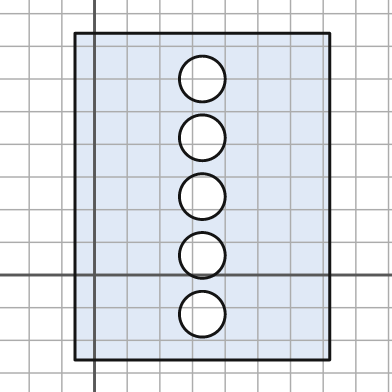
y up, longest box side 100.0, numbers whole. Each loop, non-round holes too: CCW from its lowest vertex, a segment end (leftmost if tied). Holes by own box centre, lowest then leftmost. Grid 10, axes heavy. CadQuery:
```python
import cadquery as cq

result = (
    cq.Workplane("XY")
    .moveTo(-6.0, -26.0)
    .lineTo(72.0, -26.0)
    .lineTo(72.0, 74.0)
    .lineTo(-6.0, 74.0)
    .close()
    .moveTo(33.0, -12.0)
    .circle(7.0)
    .moveTo(33.0, 6.0)
    .circle(7.0)
    .moveTo(33.0, 24.0)
    .circle(7.0)
    .moveTo(33.0, 42.0)
    .circle(7.0)
    .moveTo(33.0, 60.0)
    .circle(7.0)
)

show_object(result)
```